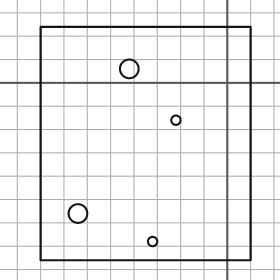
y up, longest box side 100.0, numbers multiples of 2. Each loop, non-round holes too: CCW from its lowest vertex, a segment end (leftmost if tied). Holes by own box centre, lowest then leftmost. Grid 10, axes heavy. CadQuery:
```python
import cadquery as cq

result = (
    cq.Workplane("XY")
    .moveTo(-80.0, -76.0)
    .lineTo(10.0, -76.0)
    .lineTo(10.0, 24.0)
    .lineTo(-80.0, 24.0)
    .close()
    .moveTo(-32.0, -68.0)
    .circle(2.0)
    .moveTo(-64.0, -56.0)
    .circle(4.0)
    .moveTo(-22.0, -16.0)
    .circle(2.0)
    .moveTo(-42.0, 6.0)
    .circle(4.0)
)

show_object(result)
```